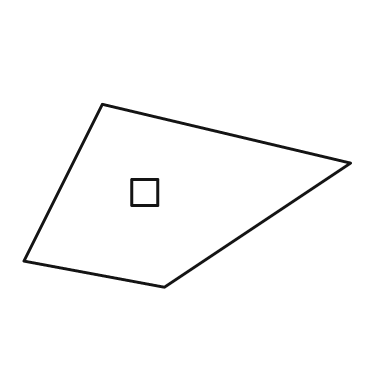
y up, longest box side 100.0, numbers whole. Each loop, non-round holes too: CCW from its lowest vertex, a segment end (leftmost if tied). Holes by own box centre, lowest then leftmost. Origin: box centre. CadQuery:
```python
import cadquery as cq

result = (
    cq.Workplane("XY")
    .moveTo(-7.0, -28.0)
    .lineTo(50.0, 10.0)
    .lineTo(-26.0, 28.0)
    .lineTo(-50.0, -20.0)
    .close()
    .moveTo(-17.0, -3.0)
    .lineTo(-9.0, -3.0)
    .lineTo(-9.0, 5.0)
    .lineTo(-17.0, 5.0)
    .close()
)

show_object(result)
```